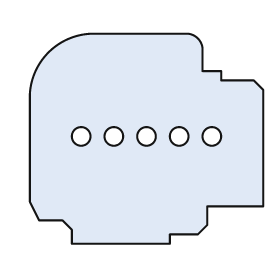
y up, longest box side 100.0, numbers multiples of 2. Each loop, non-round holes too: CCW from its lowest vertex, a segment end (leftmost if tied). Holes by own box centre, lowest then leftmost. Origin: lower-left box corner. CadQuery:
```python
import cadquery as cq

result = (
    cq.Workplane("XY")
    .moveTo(18.0, 0.0)
    .lineTo(60.0, 0.0)
    .lineTo(60.0, 4.0)
    .lineTo(72.0, 4.0)
    .lineTo(76.0, 8.0)
    .lineTo(76.0, 16.0)
    .lineTo(100.0, 16.0)
    .lineTo(100.0, 66.0)
    .lineTo(96.0, 70.0)
    .lineTo(82.0, 70.0)
    .lineTo(82.0, 74.0)
    .lineTo(74.0, 74.0)
    .lineTo(74.0, 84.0)
    .threePointArc((72.0, 88.0), (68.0, 90.0))
    .lineTo(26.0, 90.0)
    .threePointArc((8.0, 82.0), (0.0, 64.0))
    .lineTo(0.0, 18.0)
    .lineTo(4.0, 10.0)
    .lineTo(14.0, 10.0)
    .lineTo(18.0, 6.0)
    .close()
    .moveTo(22.0, 46.0)
    .circle(4.0)
    .moveTo(36.0, 46.0)
    .circle(4.0)
    .moveTo(50.0, 46.0)
    .circle(4.0)
    .moveTo(64.0, 46.0)
    .circle(4.0)
    .moveTo(78.0, 46.0)
    .circle(4.0)
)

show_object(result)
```